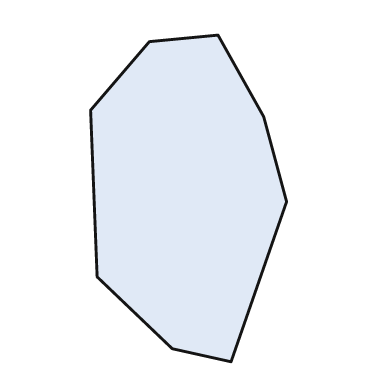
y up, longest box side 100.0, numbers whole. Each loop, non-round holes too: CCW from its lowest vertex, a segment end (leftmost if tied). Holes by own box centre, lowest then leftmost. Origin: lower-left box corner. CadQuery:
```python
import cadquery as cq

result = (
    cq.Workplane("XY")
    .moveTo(43.0, 0.0)
    .lineTo(60.0, 49.0)
    .lineTo(53.0, 75.0)
    .lineTo(39.0, 100.0)
    .lineTo(18.0, 98.0)
    .lineTo(0.0, 77.0)
    .lineTo(2.0, 26.0)
    .lineTo(25.0, 4.0)
    .close()
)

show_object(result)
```